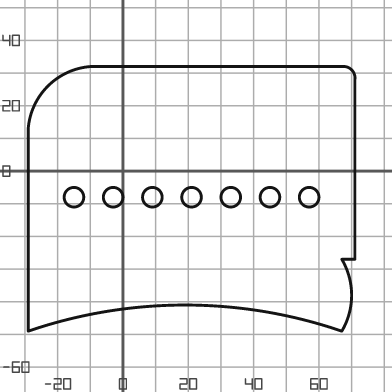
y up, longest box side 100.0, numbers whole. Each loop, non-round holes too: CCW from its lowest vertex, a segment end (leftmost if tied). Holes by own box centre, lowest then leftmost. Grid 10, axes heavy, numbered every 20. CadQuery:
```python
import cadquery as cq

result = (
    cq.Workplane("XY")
    .moveTo(-29.0, -49.0)
    .threePointArc((19.0, -41.0), (67.0, -49.0))
    .threePointArc((70.0, -38.0), (67.0, -27.0))
    .lineTo(71.0, -27.0)
    .lineTo(71.0, 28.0)
    .threePointArc((70.0, 31.0), (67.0, 32.0))
    .lineTo(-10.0, 32.0)
    .threePointArc((-23.0, 26.0), (-29.0, 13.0))
    .close()
    .moveTo(-15.0, -8.0)
    .circle(3.0)
    .moveTo(-3.0, -8.0)
    .circle(3.0)
    .moveTo(9.0, -8.0)
    .circle(3.0)
    .moveTo(21.0, -8.0)
    .circle(3.0)
    .moveTo(33.0, -8.0)
    .circle(3.0)
    .moveTo(45.0, -8.0)
    .circle(3.0)
    .moveTo(57.0, -8.0)
    .circle(3.0)
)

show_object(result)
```